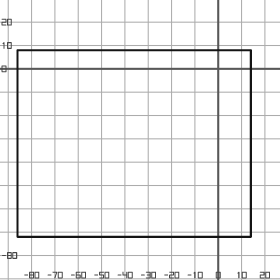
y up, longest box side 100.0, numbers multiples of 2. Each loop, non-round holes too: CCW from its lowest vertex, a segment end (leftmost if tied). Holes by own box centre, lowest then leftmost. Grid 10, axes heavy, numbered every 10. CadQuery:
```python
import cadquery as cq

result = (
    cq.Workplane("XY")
    .moveTo(-86.0, -72.0)
    .lineTo(14.0, -72.0)
    .lineTo(14.0, 8.0)
    .lineTo(-86.0, 8.0)
    .close()
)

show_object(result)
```